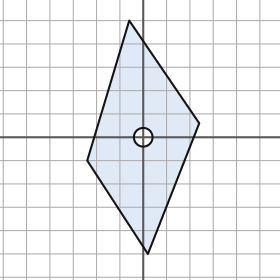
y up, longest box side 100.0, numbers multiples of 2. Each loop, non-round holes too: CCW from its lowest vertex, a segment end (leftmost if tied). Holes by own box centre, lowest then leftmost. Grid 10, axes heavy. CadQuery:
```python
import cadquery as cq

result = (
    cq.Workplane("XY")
    .moveTo(2.0, -50.0)
    .lineTo(24.0, 6.0)
    .lineTo(-6.0, 50.0)
    .lineTo(-24.0, -10.0)
    .close()
    .moveTo(0.0, 0.0)
    .circle(4.0)
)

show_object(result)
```